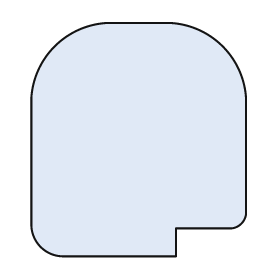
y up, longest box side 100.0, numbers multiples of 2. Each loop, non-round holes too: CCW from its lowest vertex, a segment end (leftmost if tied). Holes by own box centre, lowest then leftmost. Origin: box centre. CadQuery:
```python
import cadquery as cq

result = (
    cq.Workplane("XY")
    .moveTo(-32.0, -50.0)
    .lineTo(16.0, -50.0)
    .lineTo(16.0, -38.0)
    .lineTo(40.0, -38.0)
    .threePointArc((44.0, -36.0), (46.0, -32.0))
    .lineTo(46.0, 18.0)
    .threePointArc((36.0, 40.0), (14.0, 50.0))
    .lineTo(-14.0, 50.0)
    .threePointArc((-36.0, 40.0), (-46.0, 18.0))
    .lineTo(-46.0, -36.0)
    .threePointArc((-42.0, -46.0), (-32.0, -50.0))
    .close()
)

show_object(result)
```